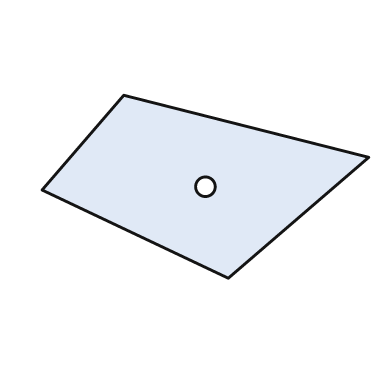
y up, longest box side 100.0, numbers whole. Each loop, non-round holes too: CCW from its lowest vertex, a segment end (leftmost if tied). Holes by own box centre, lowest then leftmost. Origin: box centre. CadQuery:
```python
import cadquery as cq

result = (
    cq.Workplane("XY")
    .moveTo(7.0, -28.0)
    .lineTo(50.0, 9.0)
    .lineTo(-25.0, 28.0)
    .lineTo(-50.0, -1.0)
    .close()
    .moveTo(0.0, 0.0)
    .circle(3.0)
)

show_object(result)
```